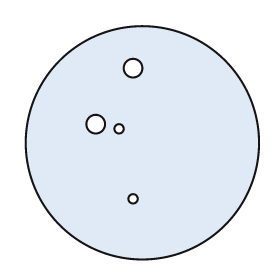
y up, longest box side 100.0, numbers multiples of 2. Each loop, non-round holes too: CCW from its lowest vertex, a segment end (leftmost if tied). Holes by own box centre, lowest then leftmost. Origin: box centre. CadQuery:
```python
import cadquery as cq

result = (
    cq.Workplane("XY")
    .moveTo(0.0, 0.0)
    .circle(50.0)
    .moveTo(-4.0, -24.0)
    .circle(2.0)
    .moveTo(-10.0, 6.0)
    .circle(2.0)
    .moveTo(-20.0, 8.0)
    .circle(4.0)
    .moveTo(-4.0, 32.0)
    .circle(4.0)
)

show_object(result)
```